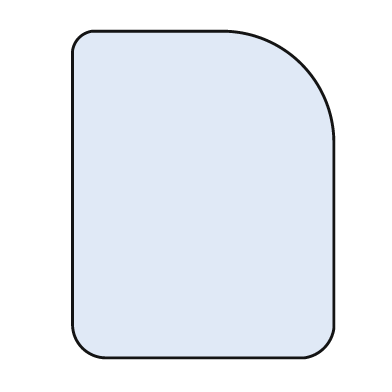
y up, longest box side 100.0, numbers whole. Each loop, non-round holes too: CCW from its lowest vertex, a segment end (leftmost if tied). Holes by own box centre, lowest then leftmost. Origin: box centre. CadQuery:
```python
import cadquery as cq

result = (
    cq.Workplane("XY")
    .moveTo(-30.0, -50.0)
    .lineTo(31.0, -50.0)
    .threePointArc((37.0, -47.0), (40.0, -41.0))
    .lineTo(40.0, 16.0)
    .threePointArc((30.0, 40.0), (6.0, 50.0))
    .lineTo(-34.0, 50.0)
    .threePointArc((-38.0, 48.0), (-40.0, 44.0))
    .lineTo(-40.0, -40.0)
    .threePointArc((-37.0, -47.0), (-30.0, -50.0))
    .close()
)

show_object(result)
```